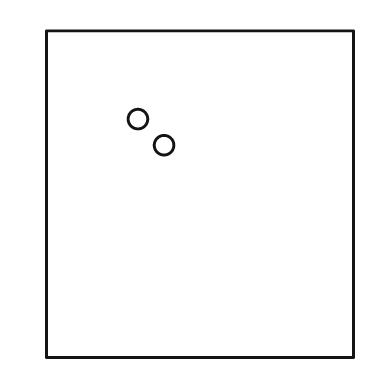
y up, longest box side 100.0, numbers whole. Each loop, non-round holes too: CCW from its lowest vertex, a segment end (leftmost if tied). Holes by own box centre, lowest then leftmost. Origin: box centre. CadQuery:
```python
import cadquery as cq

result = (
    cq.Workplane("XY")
    .moveTo(-47.0, -50.0)
    .lineTo(47.0, -50.0)
    .lineTo(47.0, 50.0)
    .lineTo(-47.0, 50.0)
    .close()
    .moveTo(-11.0, 15.0)
    .circle(3.0)
    .moveTo(-19.0, 23.0)
    .circle(3.0)
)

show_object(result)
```